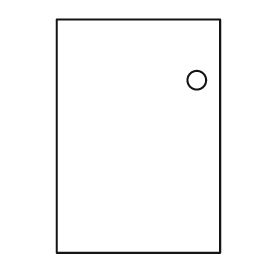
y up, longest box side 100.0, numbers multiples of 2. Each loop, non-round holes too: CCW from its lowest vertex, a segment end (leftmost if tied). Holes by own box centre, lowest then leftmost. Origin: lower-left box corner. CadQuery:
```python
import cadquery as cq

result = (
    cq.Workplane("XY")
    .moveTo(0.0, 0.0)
    .lineTo(70.0, 0.0)
    .lineTo(70.0, 100.0)
    .lineTo(0.0, 100.0)
    .close()
    .moveTo(60.0, 74.0)
    .circle(4.0)
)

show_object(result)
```